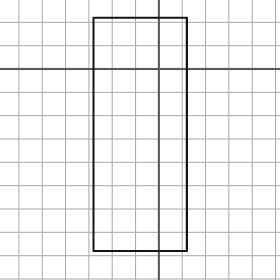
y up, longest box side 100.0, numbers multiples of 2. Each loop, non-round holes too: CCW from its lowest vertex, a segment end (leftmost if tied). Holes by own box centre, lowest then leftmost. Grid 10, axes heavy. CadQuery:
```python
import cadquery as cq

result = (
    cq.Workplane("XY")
    .moveTo(-28.0, -78.0)
    .lineTo(12.0, -78.0)
    .lineTo(12.0, 22.0)
    .lineTo(-28.0, 22.0)
    .close()
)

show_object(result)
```